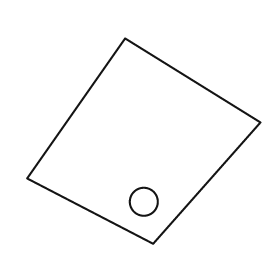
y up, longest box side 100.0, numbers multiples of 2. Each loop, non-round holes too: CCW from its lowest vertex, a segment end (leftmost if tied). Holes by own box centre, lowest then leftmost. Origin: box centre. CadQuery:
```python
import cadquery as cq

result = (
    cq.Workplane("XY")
    .moveTo(4.0, -44.0)
    .lineTo(50.0, 8.0)
    .lineTo(-8.0, 44.0)
    .lineTo(-50.0, -16.0)
    .close()
    .moveTo(0.0, -26.0)
    .circle(6.0)
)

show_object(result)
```